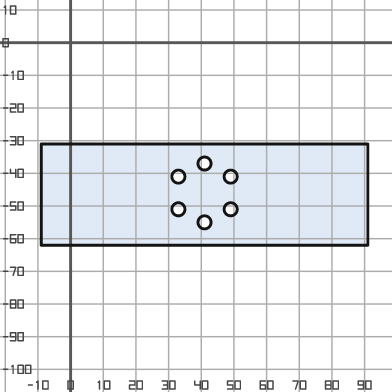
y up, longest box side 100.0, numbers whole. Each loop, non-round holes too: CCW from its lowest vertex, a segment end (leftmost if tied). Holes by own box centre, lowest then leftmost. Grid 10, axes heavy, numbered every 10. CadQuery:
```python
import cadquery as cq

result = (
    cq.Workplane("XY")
    .moveTo(-9.0, -62.0)
    .lineTo(91.0, -62.0)
    .lineTo(91.0, -31.0)
    .lineTo(-9.0, -31.0)
    .close()
    .moveTo(41.0, -55.0)
    .circle(2.0)
    .moveTo(33.0, -51.0)
    .circle(2.0)
    .moveTo(49.0, -51.0)
    .circle(2.0)
    .moveTo(33.0, -41.0)
    .circle(2.0)
    .moveTo(49.0, -41.0)
    .circle(2.0)
    .moveTo(41.0, -37.0)
    .circle(2.0)
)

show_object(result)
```